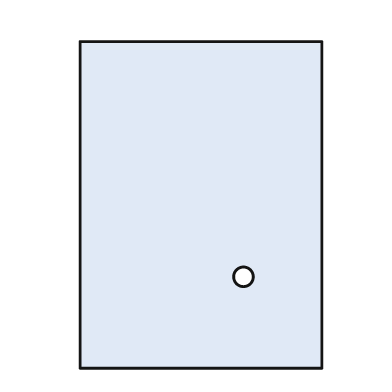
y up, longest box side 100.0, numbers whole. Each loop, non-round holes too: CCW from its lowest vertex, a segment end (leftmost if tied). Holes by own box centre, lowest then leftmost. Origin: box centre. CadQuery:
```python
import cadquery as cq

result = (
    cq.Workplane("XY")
    .moveTo(-37.0, -50.0)
    .lineTo(37.0, -50.0)
    .lineTo(37.0, 50.0)
    .lineTo(-37.0, 50.0)
    .close()
    .moveTo(13.0, -22.0)
    .circle(3.0)
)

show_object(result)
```